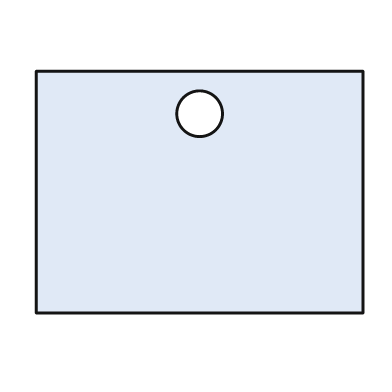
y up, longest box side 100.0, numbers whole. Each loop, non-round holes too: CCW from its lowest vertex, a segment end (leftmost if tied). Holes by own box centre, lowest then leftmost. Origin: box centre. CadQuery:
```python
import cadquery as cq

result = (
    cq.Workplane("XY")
    .moveTo(-50.0, -37.0)
    .lineTo(50.0, -37.0)
    .lineTo(50.0, 37.0)
    .lineTo(-50.0, 37.0)
    .close()
    .moveTo(0.0, 24.0)
    .circle(7.0)
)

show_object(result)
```